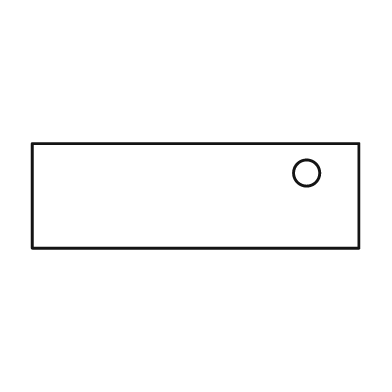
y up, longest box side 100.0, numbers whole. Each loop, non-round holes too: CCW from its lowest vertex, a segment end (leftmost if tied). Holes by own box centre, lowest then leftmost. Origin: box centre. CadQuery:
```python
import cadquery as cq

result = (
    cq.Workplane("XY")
    .moveTo(-50.0, -16.0)
    .lineTo(50.0, -16.0)
    .lineTo(50.0, 16.0)
    .lineTo(-50.0, 16.0)
    .close()
    .moveTo(34.0, 7.0)
    .circle(4.0)
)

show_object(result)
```